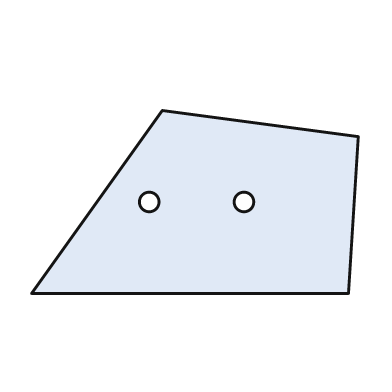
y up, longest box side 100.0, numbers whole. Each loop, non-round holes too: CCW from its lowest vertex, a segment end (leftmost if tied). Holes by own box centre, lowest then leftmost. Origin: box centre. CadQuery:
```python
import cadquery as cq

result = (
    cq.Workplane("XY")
    .moveTo(-50.0, -28.0)
    .lineTo(47.0, -28.0)
    .lineTo(50.0, 20.0)
    .lineTo(-10.0, 28.0)
    .close()
    .moveTo(-14.0, 0.0)
    .circle(3.0)
    .moveTo(15.0, 0.0)
    .circle(3.0)
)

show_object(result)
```